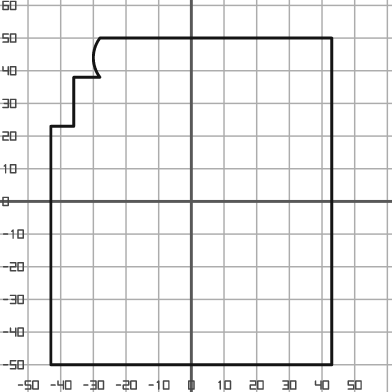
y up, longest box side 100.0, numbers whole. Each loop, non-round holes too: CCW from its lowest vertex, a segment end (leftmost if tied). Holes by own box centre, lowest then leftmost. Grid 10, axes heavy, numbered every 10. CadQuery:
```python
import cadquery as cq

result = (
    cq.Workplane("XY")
    .moveTo(-43.0, -50.0)
    .lineTo(43.0, -50.0)
    .lineTo(43.0, 50.0)
    .lineTo(-28.0, 50.0)
    .threePointArc((-30.0, 44.0), (-28.0, 38.0))
    .lineTo(-36.0, 38.0)
    .lineTo(-36.0, 23.0)
    .lineTo(-43.0, 23.0)
    .close()
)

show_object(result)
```